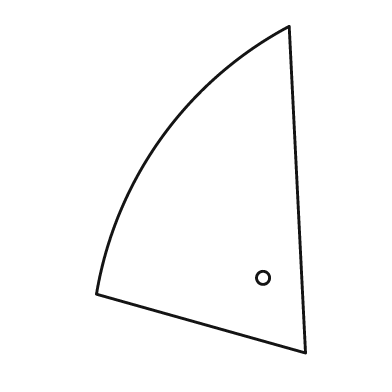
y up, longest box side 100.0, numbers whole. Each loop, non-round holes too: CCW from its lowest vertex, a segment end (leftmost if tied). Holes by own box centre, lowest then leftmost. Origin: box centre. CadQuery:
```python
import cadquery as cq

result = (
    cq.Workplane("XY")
    .moveTo(32.0, -50.0)
    .lineTo(27.0, 50.0)
    .threePointArc((-12.0, 16.0), (-32.0, -32.0))
    .close()
    .moveTo(19.0, -27.0)
    .circle(2.0)
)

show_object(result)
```